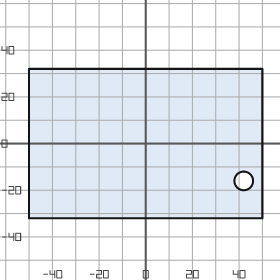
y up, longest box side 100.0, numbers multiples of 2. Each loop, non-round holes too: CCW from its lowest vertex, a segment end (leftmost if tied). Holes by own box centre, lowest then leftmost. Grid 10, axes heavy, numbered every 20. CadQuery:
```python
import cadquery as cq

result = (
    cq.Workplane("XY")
    .moveTo(-50.0, -32.0)
    .lineTo(50.0, -32.0)
    .lineTo(50.0, 32.0)
    .lineTo(-50.0, 32.0)
    .close()
    .moveTo(42.0, -16.0)
    .circle(4.0)
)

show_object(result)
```